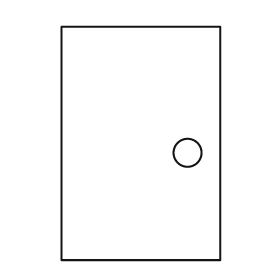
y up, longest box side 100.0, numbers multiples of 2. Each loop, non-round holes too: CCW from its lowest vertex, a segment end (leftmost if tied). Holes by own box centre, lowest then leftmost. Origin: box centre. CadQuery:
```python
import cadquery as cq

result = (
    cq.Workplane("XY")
    .moveTo(-34.0, -50.0)
    .lineTo(34.0, -50.0)
    .lineTo(34.0, 50.0)
    .lineTo(-34.0, 50.0)
    .close()
    .moveTo(20.0, -4.0)
    .circle(6.0)
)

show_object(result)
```